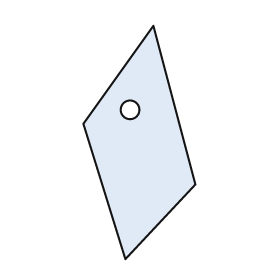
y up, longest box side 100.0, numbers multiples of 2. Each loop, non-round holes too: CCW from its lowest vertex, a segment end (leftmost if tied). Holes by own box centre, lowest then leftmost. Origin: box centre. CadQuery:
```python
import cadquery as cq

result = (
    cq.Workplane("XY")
    .moveTo(-6.0, -50.0)
    .lineTo(24.0, -18.0)
    .lineTo(6.0, 50.0)
    .lineTo(-24.0, 8.0)
    .close()
    .moveTo(-4.0, 14.0)
    .circle(4.0)
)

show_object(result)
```